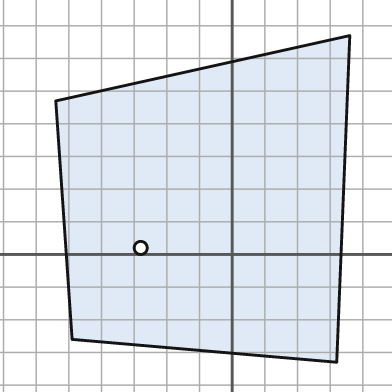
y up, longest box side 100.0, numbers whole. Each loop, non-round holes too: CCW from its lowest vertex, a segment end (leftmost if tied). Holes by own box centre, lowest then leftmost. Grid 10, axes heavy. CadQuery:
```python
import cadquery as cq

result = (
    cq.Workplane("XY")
    .moveTo(32.0, -33.0)
    .lineTo(36.0, 67.0)
    .lineTo(-54.0, 47.0)
    .lineTo(-49.0, -26.0)
    .close()
    .moveTo(-28.0, 2.0)
    .circle(2.0)
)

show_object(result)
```